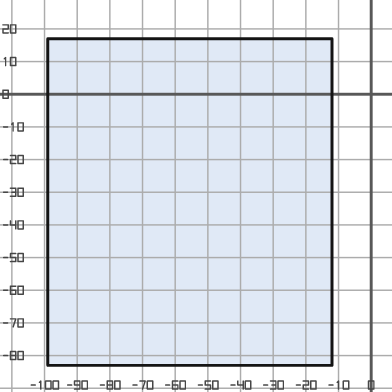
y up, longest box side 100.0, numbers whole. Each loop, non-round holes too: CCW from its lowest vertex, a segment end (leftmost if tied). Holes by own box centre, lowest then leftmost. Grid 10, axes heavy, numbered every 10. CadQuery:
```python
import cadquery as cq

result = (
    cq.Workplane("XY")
    .moveTo(-99.0, -83.0)
    .lineTo(-12.0, -83.0)
    .lineTo(-12.0, 17.0)
    .lineTo(-99.0, 17.0)
    .close()
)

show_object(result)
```